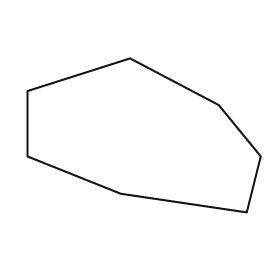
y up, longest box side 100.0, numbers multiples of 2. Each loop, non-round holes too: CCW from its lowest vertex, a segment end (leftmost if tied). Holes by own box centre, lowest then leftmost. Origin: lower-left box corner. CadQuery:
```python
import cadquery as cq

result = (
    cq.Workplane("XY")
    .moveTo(94.0, 0.0)
    .lineTo(100.0, 24.0)
    .lineTo(82.0, 46.0)
    .lineTo(44.0, 66.0)
    .lineTo(0.0, 52.0)
    .lineTo(0.0, 24.0)
    .lineTo(40.0, 8.0)
    .close()
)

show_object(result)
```